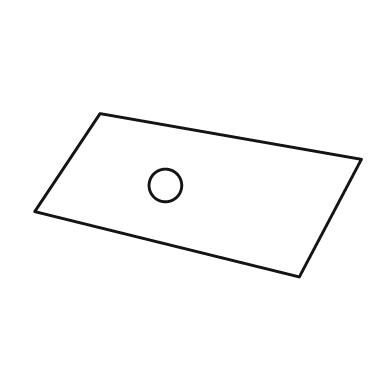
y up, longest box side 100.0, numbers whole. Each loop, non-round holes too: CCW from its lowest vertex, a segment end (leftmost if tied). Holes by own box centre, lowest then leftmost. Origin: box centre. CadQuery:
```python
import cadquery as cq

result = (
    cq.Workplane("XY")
    .moveTo(31.0, -25.0)
    .lineTo(50.0, 11.0)
    .lineTo(-30.0, 25.0)
    .lineTo(-50.0, -5.0)
    .close()
    .moveTo(-10.0, 3.0)
    .circle(5.0)
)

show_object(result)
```